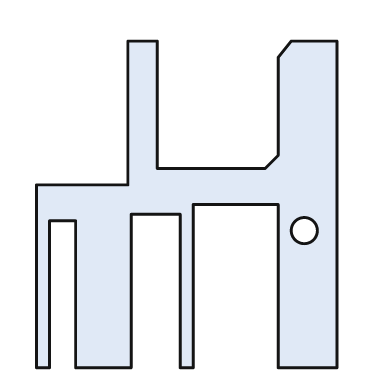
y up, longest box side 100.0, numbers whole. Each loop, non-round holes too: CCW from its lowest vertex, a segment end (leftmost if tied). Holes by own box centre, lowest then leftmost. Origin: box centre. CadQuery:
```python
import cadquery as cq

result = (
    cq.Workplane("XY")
    .moveTo(-46.0, -50.0)
    .lineTo(-42.0, -50.0)
    .lineTo(-42.0, -5.0)
    .lineTo(-34.0, -5.0)
    .lineTo(-34.0, -50.0)
    .lineTo(-17.0, -50.0)
    .lineTo(-17.0, -3.0)
    .lineTo(-2.0, -3.0)
    .lineTo(-2.0, -50.0)
    .lineTo(2.0, -50.0)
    .lineTo(2.0, 0.0)
    .lineTo(28.0, 0.0)
    .lineTo(28.0, -50.0)
    .lineTo(46.0, -50.0)
    .lineTo(46.0, 50.0)
    .lineTo(32.0, 50.0)
    .lineTo(28.0, 45.0)
    .lineTo(28.0, 15.0)
    .lineTo(24.0, 11.0)
    .lineTo(-9.0, 11.0)
    .lineTo(-9.0, 50.0)
    .lineTo(-18.0, 50.0)
    .lineTo(-18.0, 6.0)
    .lineTo(-46.0, 6.0)
    .close()
    .moveTo(36.0, -8.0)
    .circle(4.0)
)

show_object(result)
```